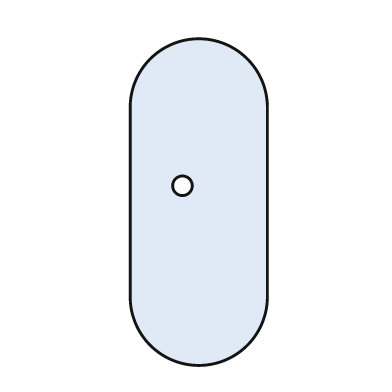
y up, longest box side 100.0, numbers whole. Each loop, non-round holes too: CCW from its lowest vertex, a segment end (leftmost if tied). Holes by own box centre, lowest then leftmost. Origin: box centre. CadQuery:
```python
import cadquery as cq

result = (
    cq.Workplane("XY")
    .moveTo(-21.0, -29.0)
    .threePointArc((0.0, -50.0), (21.0, -29.0))
    .lineTo(21.0, 29.0)
    .threePointArc((0.0, 50.0), (-21.0, 29.0))
    .close()
    .moveTo(-5.0, 5.0)
    .circle(3.0)
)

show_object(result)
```